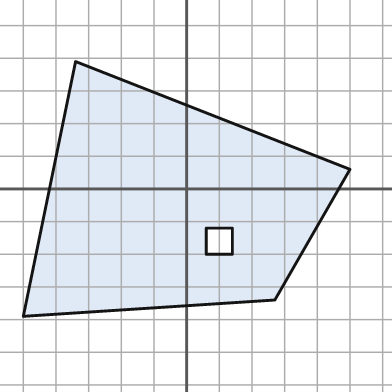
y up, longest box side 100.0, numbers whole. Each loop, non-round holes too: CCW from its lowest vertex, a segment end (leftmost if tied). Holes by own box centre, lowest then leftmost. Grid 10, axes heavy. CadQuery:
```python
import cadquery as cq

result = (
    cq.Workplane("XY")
    .moveTo(-50.0, -39.0)
    .lineTo(27.0, -34.0)
    .lineTo(50.0, 6.0)
    .lineTo(-34.0, 39.0)
    .close()
    .moveTo(6.0, -20.0)
    .lineTo(14.0, -20.0)
    .lineTo(14.0, -12.0)
    .lineTo(6.0, -12.0)
    .close()
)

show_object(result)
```